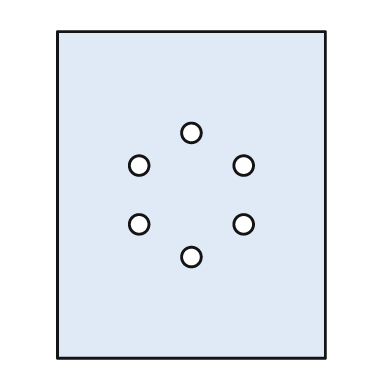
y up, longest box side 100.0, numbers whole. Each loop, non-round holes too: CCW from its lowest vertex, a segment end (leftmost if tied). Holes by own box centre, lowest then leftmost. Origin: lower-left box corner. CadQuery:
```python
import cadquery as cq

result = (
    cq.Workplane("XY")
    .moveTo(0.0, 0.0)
    .lineTo(82.0, 0.0)
    .lineTo(82.0, 100.0)
    .lineTo(0.0, 100.0)
    .close()
    .moveTo(41.0, 31.0)
    .circle(3.0)
    .moveTo(25.0, 41.0)
    .circle(3.0)
    .moveTo(57.0, 41.0)
    .circle(3.0)
    .moveTo(25.0, 59.0)
    .circle(3.0)
    .moveTo(57.0, 59.0)
    .circle(3.0)
    .moveTo(41.0, 69.0)
    .circle(3.0)
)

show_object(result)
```